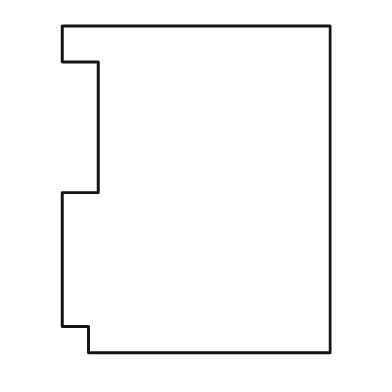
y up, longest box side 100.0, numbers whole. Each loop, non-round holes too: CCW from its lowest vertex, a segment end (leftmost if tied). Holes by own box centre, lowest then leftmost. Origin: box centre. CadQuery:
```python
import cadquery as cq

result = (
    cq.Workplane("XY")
    .moveTo(-33.0, -50.0)
    .lineTo(41.0, -50.0)
    .lineTo(41.0, 50.0)
    .lineTo(-41.0, 50.0)
    .lineTo(-41.0, 39.0)
    .lineTo(-30.0, 39.0)
    .lineTo(-30.0, -1.0)
    .lineTo(-41.0, -1.0)
    .lineTo(-41.0, -42.0)
    .lineTo(-33.0, -42.0)
    .close()
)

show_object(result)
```